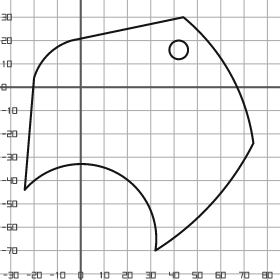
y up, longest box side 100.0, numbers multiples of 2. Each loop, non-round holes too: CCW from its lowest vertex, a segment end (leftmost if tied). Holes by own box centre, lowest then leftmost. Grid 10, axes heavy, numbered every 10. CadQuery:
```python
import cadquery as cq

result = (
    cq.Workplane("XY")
    .moveTo(32.0, -70.0)
    .threePointArc((56.0, -50.0), (74.0, -24.0))
    .threePointArc((64.0, 6.0), (44.0, 30.0))
    .lineTo(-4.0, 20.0)
    .threePointArc((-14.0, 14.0), (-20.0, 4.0))
    .lineTo(-24.0, -44.0)
    .threePointArc((14.0, -36.0), (32.0, -70.0))
    .close()
    .moveTo(42.0, 16.0)
    .circle(4.0)
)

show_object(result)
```